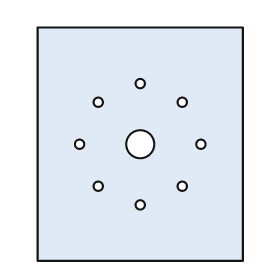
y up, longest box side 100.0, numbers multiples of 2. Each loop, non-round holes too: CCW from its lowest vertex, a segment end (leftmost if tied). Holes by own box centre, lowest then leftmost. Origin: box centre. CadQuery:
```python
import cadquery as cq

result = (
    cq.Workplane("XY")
    .moveTo(-44.0, -50.0)
    .lineTo(44.0, -50.0)
    .lineTo(44.0, 50.0)
    .lineTo(-44.0, 50.0)
    .close()
    .moveTo(0.0, -26.0)
    .circle(2.0)
    .moveTo(-18.0, -18.0)
    .circle(2.0)
    .moveTo(18.0, -18.0)
    .circle(2.0)
    .moveTo(-26.0, 0.0)
    .circle(2.0)
    .moveTo(0.0, 0.0)
    .circle(6.0)
    .moveTo(26.0, 0.0)
    .circle(2.0)
    .moveTo(-18.0, 18.0)
    .circle(2.0)
    .moveTo(18.0, 18.0)
    .circle(2.0)
    .moveTo(0.0, 26.0)
    .circle(2.0)
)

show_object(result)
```